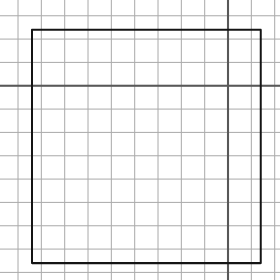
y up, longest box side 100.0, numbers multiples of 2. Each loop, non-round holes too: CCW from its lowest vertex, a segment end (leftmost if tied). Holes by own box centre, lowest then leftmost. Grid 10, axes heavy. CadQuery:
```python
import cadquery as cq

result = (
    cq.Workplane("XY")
    .moveTo(-84.0, -76.0)
    .lineTo(14.0, -76.0)
    .lineTo(14.0, 24.0)
    .lineTo(-84.0, 24.0)
    .close()
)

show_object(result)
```